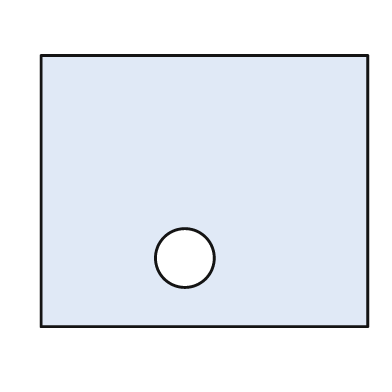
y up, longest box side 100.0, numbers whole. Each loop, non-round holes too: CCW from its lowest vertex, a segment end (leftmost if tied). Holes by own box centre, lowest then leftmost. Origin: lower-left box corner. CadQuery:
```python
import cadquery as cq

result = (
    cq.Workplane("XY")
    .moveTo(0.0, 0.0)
    .lineTo(100.0, 0.0)
    .lineTo(100.0, 83.0)
    .lineTo(0.0, 83.0)
    .close()
    .moveTo(44.0, 21.0)
    .circle(9.0)
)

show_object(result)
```